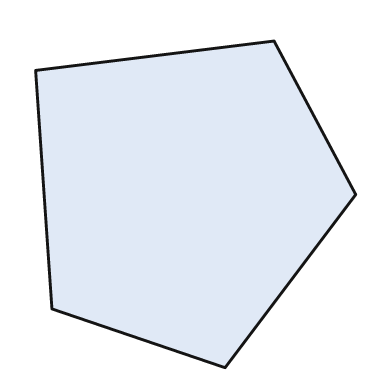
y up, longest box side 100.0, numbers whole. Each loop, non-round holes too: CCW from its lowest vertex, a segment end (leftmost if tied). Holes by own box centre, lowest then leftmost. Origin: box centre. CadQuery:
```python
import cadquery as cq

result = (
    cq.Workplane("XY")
    .moveTo(9.0, -50.0)
    .lineTo(49.0, 3.0)
    .lineTo(24.0, 50.0)
    .lineTo(-49.0, 41.0)
    .lineTo(-44.0, -32.0)
    .close()
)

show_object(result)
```